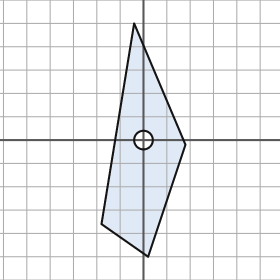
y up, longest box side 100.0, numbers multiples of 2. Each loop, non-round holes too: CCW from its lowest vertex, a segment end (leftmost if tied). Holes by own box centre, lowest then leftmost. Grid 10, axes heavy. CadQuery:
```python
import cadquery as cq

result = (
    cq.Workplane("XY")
    .moveTo(2.0, -50.0)
    .lineTo(18.0, -2.0)
    .lineTo(-4.0, 50.0)
    .lineTo(-18.0, -36.0)
    .close()
    .moveTo(0.0, 0.0)
    .circle(4.0)
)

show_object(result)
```